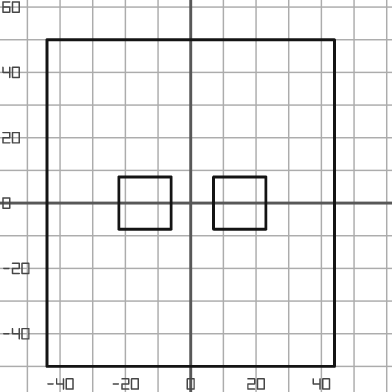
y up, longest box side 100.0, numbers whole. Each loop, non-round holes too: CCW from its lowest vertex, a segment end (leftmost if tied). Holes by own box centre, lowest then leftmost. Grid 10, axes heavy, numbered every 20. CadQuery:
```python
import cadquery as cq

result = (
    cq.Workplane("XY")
    .moveTo(-44.0, -50.0)
    .lineTo(44.0, -50.0)
    .lineTo(44.0, 50.0)
    .lineTo(-44.0, 50.0)
    .close()
    .moveTo(-22.0, -8.0)
    .lineTo(-6.0, -8.0)
    .lineTo(-6.0, 8.0)
    .lineTo(-22.0, 8.0)
    .close()
    .moveTo(7.0, -8.0)
    .lineTo(23.0, -8.0)
    .lineTo(23.0, 8.0)
    .lineTo(7.0, 8.0)
    .close()
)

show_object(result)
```